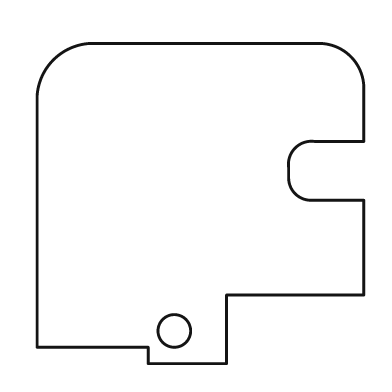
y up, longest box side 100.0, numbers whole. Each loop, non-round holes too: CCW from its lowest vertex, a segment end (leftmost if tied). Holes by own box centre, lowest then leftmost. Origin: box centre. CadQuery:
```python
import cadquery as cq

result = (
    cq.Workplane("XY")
    .moveTo(-16.0, -49.0)
    .lineTo(8.0, -49.0)
    .lineTo(8.0, -28.0)
    .lineTo(50.0, -28.0)
    .lineTo(50.0, 1.0)
    .lineTo(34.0, 1.0)
    .threePointArc((29.0, 3.0), (27.0, 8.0))
    .lineTo(27.0, 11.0)
    .threePointArc((29.0, 17.0), (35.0, 19.0))
    .lineTo(50.0, 19.0)
    .lineTo(50.0, 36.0)
    .threePointArc((46.0, 45.0), (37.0, 49.0))
    .lineTo(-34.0, 49.0)
    .threePointArc((-45.0, 44.0), (-50.0, 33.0))
    .lineTo(-50.0, -44.0)
    .lineTo(-16.0, -44.0)
    .close()
    .moveTo(-8.0, -39.0)
    .circle(5.0)
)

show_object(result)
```